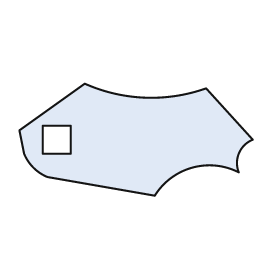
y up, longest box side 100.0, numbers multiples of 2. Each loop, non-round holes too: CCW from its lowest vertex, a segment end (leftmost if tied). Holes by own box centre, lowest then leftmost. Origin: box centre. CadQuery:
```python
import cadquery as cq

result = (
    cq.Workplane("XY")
    .moveTo(8.0, -24.0)
    .threePointArc((24.0, -12.0), (44.0, -14.0))
    .threePointArc((44.0, -6.0), (50.0, 0.0))
    .lineTo(30.0, 22.0)
    .threePointArc((4.0, 18.0), (-22.0, 24.0))
    .lineTo(-50.0, 4.0)
    .lineTo(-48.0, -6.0)
    .threePointArc((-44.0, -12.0), (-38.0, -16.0))
    .close()
    .moveTo(-40.0, -6.0)
    .lineTo(-28.0, -6.0)
    .lineTo(-28.0, 6.0)
    .lineTo(-40.0, 6.0)
    .close()
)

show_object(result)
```